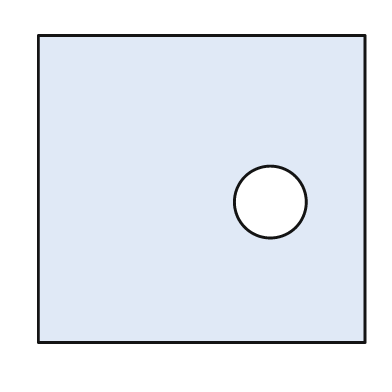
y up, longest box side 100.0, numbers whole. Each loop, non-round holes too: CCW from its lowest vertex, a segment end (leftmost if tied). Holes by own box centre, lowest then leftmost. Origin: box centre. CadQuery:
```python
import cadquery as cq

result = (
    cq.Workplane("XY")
    .moveTo(-50.0, -47.0)
    .lineTo(50.0, -47.0)
    .lineTo(50.0, 47.0)
    .lineTo(-50.0, 47.0)
    .close()
    .moveTo(21.0, -4.0)
    .circle(11.0)
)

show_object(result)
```